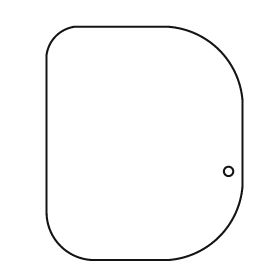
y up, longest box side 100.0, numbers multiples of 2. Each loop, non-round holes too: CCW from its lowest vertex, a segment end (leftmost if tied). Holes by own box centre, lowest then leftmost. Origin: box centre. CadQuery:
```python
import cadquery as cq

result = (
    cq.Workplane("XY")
    .moveTo(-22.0, -50.0)
    .lineTo(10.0, -50.0)
    .threePointArc((32.0, -40.0), (42.0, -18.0))
    .lineTo(42.0, 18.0)
    .threePointArc((32.0, 40.0), (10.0, 50.0))
    .lineTo(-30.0, 50.0)
    .threePointArc((-38.0, 46.0), (-42.0, 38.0))
    .lineTo(-42.0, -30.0)
    .threePointArc((-36.0, -44.0), (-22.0, -50.0))
    .close()
    .moveTo(36.0, -12.0)
    .circle(2.0)
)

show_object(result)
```